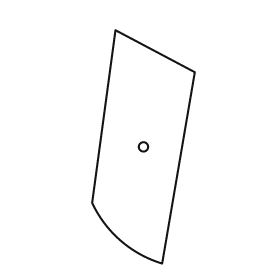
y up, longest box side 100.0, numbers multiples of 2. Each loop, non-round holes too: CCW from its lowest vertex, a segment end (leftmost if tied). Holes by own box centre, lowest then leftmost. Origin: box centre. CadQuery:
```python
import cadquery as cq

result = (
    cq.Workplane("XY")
    .moveTo(8.0, -50.0)
    .lineTo(22.0, 32.0)
    .lineTo(-12.0, 50.0)
    .lineTo(-22.0, -24.0)
    .threePointArc((-10.0, -40.0), (8.0, -50.0))
    .close()
    .moveTo(0.0, 0.0)
    .circle(2.0)
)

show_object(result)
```